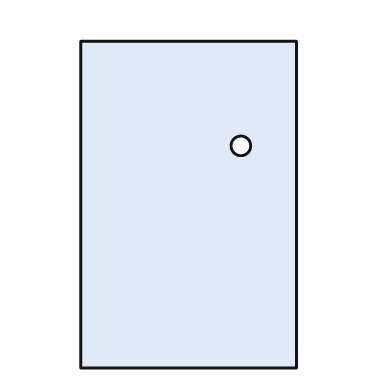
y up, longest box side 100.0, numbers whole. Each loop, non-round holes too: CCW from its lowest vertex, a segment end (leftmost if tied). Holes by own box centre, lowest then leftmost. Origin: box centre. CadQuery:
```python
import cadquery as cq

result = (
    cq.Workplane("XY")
    .moveTo(-33.0, -50.0)
    .lineTo(33.0, -50.0)
    .lineTo(33.0, 50.0)
    .lineTo(-33.0, 50.0)
    .close()
    .moveTo(16.0, 18.0)
    .circle(3.0)
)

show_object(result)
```